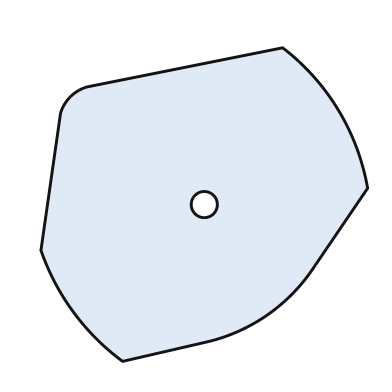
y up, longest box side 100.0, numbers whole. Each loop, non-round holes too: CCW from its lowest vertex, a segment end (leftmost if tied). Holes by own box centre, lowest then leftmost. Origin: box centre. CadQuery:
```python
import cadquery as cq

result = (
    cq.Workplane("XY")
    .moveTo(-25.0, -48.0)
    .lineTo(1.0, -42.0)
    .threePointArc((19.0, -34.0), (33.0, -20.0))
    .lineTo(50.0, 5.0)
    .threePointArc((41.0, 29.0), (24.0, 48.0))
    .lineTo(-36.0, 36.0)
    .threePointArc((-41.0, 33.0), (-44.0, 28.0))
    .lineTo(-50.0, -14.0)
    .threePointArc((-40.0, -33.0), (-25.0, -48.0))
    .close()
    .moveTo(0.0, 0.0)
    .circle(4.0)
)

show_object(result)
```